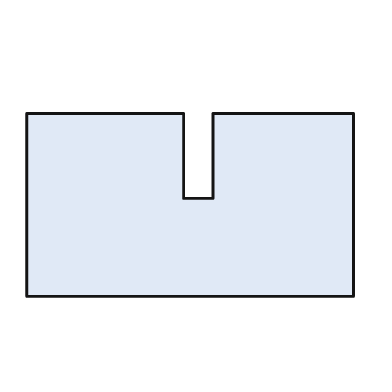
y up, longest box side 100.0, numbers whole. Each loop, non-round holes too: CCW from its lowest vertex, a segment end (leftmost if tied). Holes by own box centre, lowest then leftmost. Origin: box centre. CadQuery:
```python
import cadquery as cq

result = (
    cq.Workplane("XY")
    .moveTo(-50.0, -28.0)
    .lineTo(50.0, -28.0)
    .lineTo(50.0, 28.0)
    .lineTo(7.0, 28.0)
    .lineTo(7.0, 2.0)
    .lineTo(-2.0, 2.0)
    .lineTo(-2.0, 28.0)
    .lineTo(-50.0, 28.0)
    .close()
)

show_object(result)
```